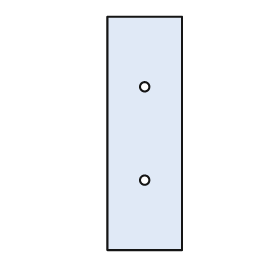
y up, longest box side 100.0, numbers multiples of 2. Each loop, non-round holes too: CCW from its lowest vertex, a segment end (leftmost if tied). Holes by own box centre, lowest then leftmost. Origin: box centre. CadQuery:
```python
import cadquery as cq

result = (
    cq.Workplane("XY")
    .moveTo(-16.0, -50.0)
    .lineTo(16.0, -50.0)
    .lineTo(16.0, 50.0)
    .lineTo(-16.0, 50.0)
    .close()
    .moveTo(0.0, -20.0)
    .circle(2.0)
    .moveTo(0.0, 20.0)
    .circle(2.0)
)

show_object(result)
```